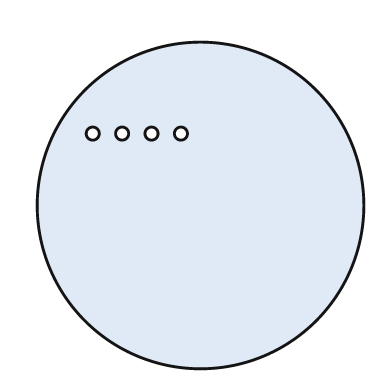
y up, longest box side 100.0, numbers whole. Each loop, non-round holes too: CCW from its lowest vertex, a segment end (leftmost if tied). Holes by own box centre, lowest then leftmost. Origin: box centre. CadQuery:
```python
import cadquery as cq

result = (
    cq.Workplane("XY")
    .moveTo(0.0, 0.0)
    .circle(50.0)
    .moveTo(-33.0, 22.0)
    .circle(2.0)
    .moveTo(-24.0, 22.0)
    .circle(2.0)
    .moveTo(-15.0, 22.0)
    .circle(2.0)
    .moveTo(-6.0, 22.0)
    .circle(2.0)
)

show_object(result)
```